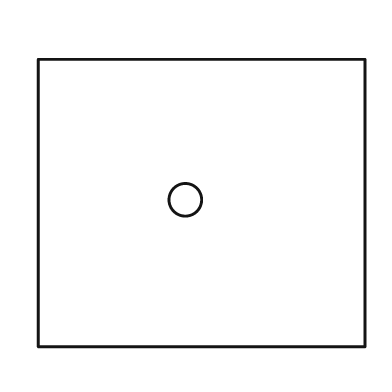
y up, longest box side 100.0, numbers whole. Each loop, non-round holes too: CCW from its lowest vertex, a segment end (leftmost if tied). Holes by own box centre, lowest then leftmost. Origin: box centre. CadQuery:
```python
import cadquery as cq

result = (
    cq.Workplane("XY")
    .moveTo(-50.0, -44.0)
    .lineTo(50.0, -44.0)
    .lineTo(50.0, 44.0)
    .lineTo(-50.0, 44.0)
    .close()
    .moveTo(-5.0, 1.0)
    .circle(5.0)
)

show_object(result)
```